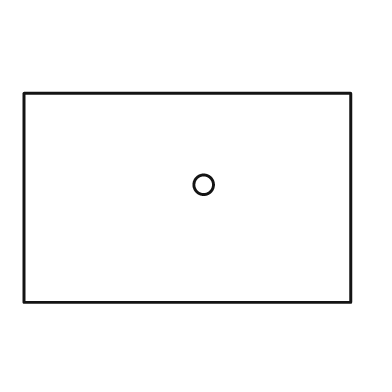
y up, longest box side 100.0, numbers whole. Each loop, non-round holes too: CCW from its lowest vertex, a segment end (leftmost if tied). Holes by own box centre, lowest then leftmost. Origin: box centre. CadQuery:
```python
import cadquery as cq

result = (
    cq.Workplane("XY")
    .moveTo(-50.0, -32.0)
    .lineTo(50.0, -32.0)
    .lineTo(50.0, 32.0)
    .lineTo(-50.0, 32.0)
    .close()
    .moveTo(5.0, 4.0)
    .circle(3.0)
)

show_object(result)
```